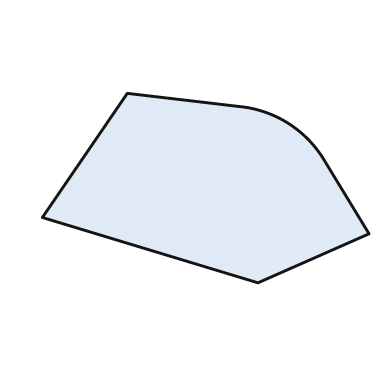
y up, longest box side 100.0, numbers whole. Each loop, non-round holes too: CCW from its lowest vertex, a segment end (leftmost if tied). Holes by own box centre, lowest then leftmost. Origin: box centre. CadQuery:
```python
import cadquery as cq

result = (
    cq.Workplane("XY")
    .moveTo(16.0, -29.0)
    .lineTo(50.0, -14.0)
    .lineTo(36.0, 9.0)
    .threePointArc((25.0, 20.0), (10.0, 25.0))
    .lineTo(-24.0, 29.0)
    .lineTo(-50.0, -9.0)
    .close()
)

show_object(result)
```